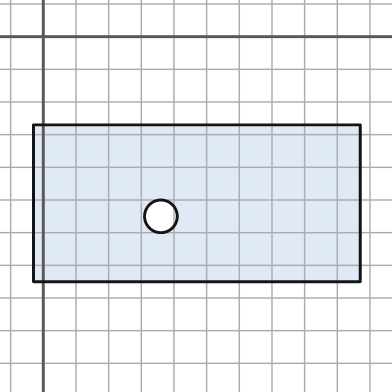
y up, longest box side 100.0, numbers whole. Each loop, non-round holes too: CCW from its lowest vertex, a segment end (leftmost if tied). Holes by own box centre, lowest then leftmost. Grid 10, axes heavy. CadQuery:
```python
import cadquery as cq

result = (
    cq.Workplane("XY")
    .moveTo(-3.0, -75.0)
    .lineTo(97.0, -75.0)
    .lineTo(97.0, -27.0)
    .lineTo(-3.0, -27.0)
    .close()
    .moveTo(36.0, -55.0)
    .circle(5.0)
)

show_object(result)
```